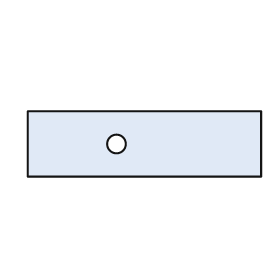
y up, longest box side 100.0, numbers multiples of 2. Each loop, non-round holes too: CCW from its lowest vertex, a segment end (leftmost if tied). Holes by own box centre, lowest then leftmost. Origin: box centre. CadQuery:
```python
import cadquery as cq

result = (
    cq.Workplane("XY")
    .moveTo(-50.0, -14.0)
    .lineTo(50.0, -14.0)
    .lineTo(50.0, 14.0)
    .lineTo(-50.0, 14.0)
    .close()
    .moveTo(-12.0, 0.0)
    .circle(4.0)
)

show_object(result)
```